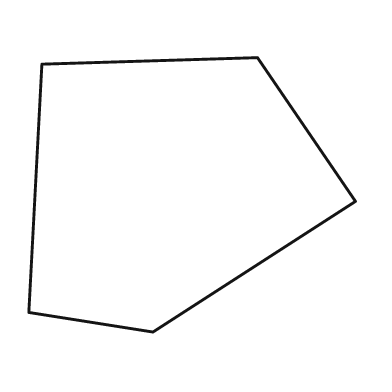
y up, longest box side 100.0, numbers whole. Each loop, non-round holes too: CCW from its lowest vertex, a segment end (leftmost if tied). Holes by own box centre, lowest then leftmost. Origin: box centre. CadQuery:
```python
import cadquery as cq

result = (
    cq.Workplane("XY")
    .moveTo(-12.0, -42.0)
    .lineTo(50.0, -2.0)
    .lineTo(20.0, 42.0)
    .lineTo(-46.0, 40.0)
    .lineTo(-50.0, -36.0)
    .close()
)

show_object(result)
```